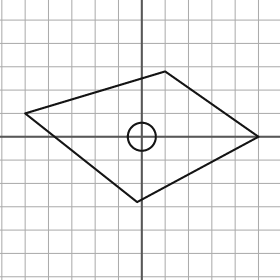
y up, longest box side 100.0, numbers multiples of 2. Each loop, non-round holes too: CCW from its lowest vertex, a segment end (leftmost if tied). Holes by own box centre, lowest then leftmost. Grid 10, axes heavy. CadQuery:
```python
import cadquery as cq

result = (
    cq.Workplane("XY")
    .moveTo(-2.0, -28.0)
    .lineTo(50.0, 0.0)
    .lineTo(10.0, 28.0)
    .lineTo(-50.0, 10.0)
    .close()
    .moveTo(0.0, 0.0)
    .circle(6.0)
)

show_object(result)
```